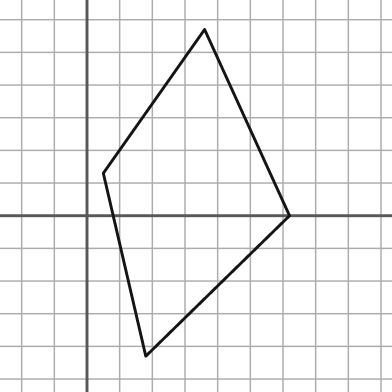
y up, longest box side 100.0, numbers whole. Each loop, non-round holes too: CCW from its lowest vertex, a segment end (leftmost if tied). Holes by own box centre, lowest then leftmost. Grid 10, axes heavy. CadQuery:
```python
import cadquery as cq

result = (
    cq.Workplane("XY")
    .moveTo(18.0, -43.0)
    .lineTo(62.0, 0.0)
    .lineTo(36.0, 57.0)
    .lineTo(5.0, 13.0)
    .close()
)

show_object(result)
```